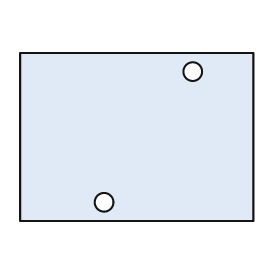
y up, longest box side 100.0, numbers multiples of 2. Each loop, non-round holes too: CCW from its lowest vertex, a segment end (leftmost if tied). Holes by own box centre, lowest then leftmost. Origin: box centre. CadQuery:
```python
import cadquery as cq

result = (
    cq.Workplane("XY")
    .moveTo(-50.0, -36.0)
    .lineTo(50.0, -36.0)
    .lineTo(50.0, 36.0)
    .lineTo(-50.0, 36.0)
    .close()
    .moveTo(-14.0, -28.0)
    .circle(4.0)
    .moveTo(24.0, 28.0)
    .circle(4.0)
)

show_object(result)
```